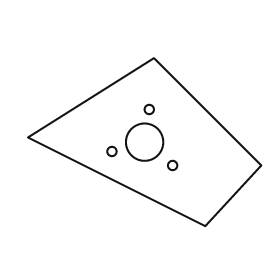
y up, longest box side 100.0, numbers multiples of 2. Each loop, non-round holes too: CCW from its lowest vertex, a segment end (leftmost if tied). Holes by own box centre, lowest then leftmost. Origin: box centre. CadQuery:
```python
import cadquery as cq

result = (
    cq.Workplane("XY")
    .moveTo(26.0, -36.0)
    .lineTo(50.0, -10.0)
    .lineTo(4.0, 36.0)
    .lineTo(-50.0, 2.0)
    .close()
    .moveTo(12.0, -10.0)
    .circle(2.0)
    .moveTo(-14.0, -4.0)
    .circle(2.0)
    .moveTo(0.0, 0.0)
    .circle(8.0)
    .moveTo(2.0, 14.0)
    .circle(2.0)
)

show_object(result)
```